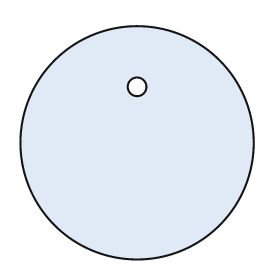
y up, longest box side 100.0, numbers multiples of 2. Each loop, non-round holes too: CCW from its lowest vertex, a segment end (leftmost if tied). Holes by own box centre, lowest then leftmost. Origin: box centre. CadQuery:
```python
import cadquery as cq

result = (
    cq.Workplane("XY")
    .moveTo(0.0, 0.0)
    .circle(50.0)
    .moveTo(0.0, 24.0)
    .circle(4.0)
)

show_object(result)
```